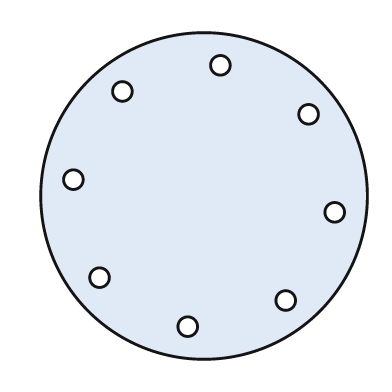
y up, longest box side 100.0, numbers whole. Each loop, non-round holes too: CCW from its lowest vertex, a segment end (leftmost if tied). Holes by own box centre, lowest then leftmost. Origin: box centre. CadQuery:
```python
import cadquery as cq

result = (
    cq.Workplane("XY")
    .moveTo(0.0, 0.0)
    .circle(50.0)
    .moveTo(-5.0, -40.0)
    .circle(3.0)
    .moveTo(25.0, -32.0)
    .circle(3.0)
    .moveTo(-32.0, -25.0)
    .circle(3.0)
    .moveTo(40.0, -5.0)
    .circle(3.0)
    .moveTo(-40.0, 5.0)
    .circle(3.0)
    .moveTo(32.0, 25.0)
    .circle(3.0)
    .moveTo(-25.0, 32.0)
    .circle(3.0)
    .moveTo(5.0, 40.0)
    .circle(3.0)
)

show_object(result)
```